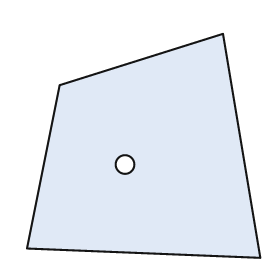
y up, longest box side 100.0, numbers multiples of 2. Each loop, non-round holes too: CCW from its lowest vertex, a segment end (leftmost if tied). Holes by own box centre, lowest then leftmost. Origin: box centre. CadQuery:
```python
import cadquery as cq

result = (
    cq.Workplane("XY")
    .moveTo(50.0, -48.0)
    .lineTo(34.0, 48.0)
    .lineTo(-36.0, 26.0)
    .lineTo(-50.0, -44.0)
    .close()
    .moveTo(-8.0, -8.0)
    .circle(4.0)
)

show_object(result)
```